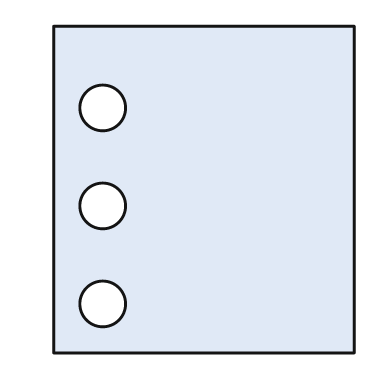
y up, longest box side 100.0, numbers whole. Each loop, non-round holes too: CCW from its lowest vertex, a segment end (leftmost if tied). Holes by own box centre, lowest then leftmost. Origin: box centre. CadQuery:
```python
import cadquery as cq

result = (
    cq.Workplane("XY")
    .moveTo(-46.0, -50.0)
    .lineTo(46.0, -50.0)
    .lineTo(46.0, 50.0)
    .lineTo(-46.0, 50.0)
    .close()
    .moveTo(-31.0, -35.0)
    .circle(7.0)
    .moveTo(-31.0, -5.0)
    .circle(7.0)
    .moveTo(-31.0, 25.0)
    .circle(7.0)
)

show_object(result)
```